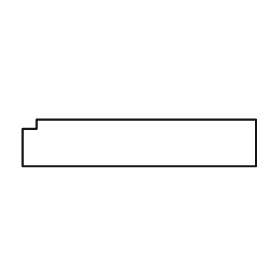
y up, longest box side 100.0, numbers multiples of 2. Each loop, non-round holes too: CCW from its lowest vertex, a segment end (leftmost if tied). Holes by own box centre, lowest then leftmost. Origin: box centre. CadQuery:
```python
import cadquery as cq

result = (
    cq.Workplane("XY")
    .moveTo(-50.0, -10.0)
    .lineTo(50.0, -10.0)
    .lineTo(50.0, 10.0)
    .lineTo(-44.0, 10.0)
    .lineTo(-44.0, 6.0)
    .lineTo(-50.0, 6.0)
    .close()
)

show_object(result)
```